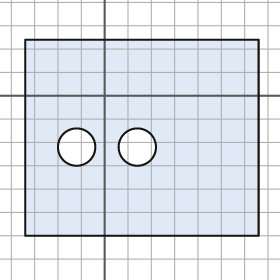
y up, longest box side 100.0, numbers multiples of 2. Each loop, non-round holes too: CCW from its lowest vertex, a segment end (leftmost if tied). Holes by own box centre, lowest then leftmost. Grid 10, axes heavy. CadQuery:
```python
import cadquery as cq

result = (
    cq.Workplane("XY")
    .moveTo(-34.0, -60.0)
    .lineTo(66.0, -60.0)
    .lineTo(66.0, 24.0)
    .lineTo(-34.0, 24.0)
    .close()
    .moveTo(-12.0, -22.0)
    .circle(8.0)
    .moveTo(14.0, -22.0)
    .circle(8.0)
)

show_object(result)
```